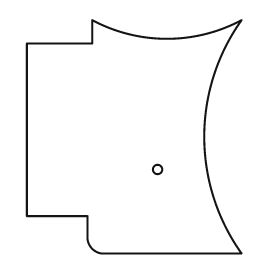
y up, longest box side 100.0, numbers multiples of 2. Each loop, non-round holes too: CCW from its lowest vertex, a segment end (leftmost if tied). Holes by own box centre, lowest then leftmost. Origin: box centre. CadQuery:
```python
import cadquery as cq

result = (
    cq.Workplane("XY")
    .moveTo(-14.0, -50.0)
    .lineTo(46.0, -50.0)
    .threePointArc((30.0, 0.0), (46.0, 50.0))
    .threePointArc((14.0, 42.0), (-18.0, 50.0))
    .lineTo(-18.0, 40.0)
    .lineTo(-46.0, 40.0)
    .lineTo(-46.0, -34.0)
    .lineTo(-20.0, -34.0)
    .lineTo(-20.0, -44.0)
    .threePointArc((-18.0, -48.0), (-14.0, -50.0))
    .close()
    .moveTo(10.0, -14.0)
    .circle(2.0)
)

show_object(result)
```